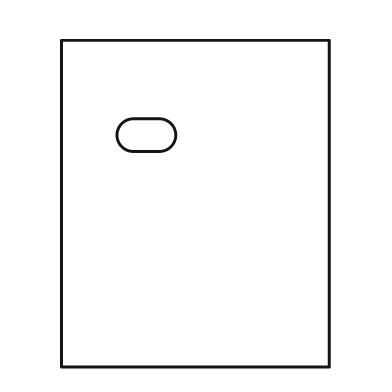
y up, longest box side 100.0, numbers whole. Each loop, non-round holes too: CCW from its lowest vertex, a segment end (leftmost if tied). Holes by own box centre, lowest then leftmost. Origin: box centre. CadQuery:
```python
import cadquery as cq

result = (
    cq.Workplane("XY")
    .moveTo(-41.0, -50.0)
    .lineTo(41.0, -50.0)
    .lineTo(41.0, 50.0)
    .lineTo(-41.0, 50.0)
    .close()
    .moveTo(-19.0, 16.0)
    .lineTo(-11.0, 16.0)
    .threePointArc((-6.0, 21.0), (-11.0, 26.0))
    .lineTo(-19.0, 26.0)
    .threePointArc((-24.0, 21.0), (-19.0, 16.0))
    .close()
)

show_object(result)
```